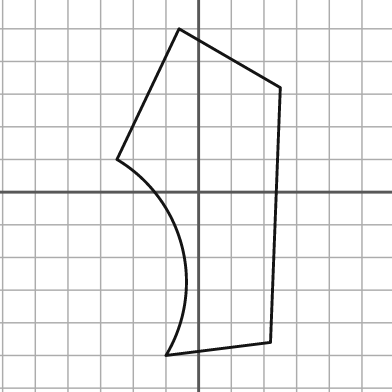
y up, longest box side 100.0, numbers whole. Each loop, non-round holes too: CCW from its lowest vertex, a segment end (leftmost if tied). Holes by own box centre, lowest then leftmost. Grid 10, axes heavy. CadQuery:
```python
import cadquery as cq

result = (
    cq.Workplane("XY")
    .moveTo(-10.0, -50.0)
    .lineTo(22.0, -46.0)
    .lineTo(25.0, 32.0)
    .lineTo(-6.0, 50.0)
    .lineTo(-25.0, 10.0)
    .threePointArc((-5.0, -17.0), (-10.0, -50.0))
    .close()
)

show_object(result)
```